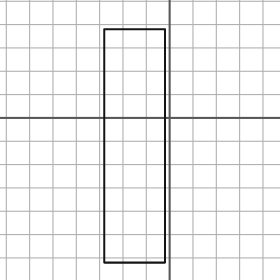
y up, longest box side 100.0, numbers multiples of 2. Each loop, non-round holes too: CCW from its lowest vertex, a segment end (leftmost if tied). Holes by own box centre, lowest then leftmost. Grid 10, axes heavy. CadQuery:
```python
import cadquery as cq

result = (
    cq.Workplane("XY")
    .moveTo(-28.0, -62.0)
    .lineTo(-2.0, -62.0)
    .lineTo(-2.0, 38.0)
    .lineTo(-28.0, 38.0)
    .close()
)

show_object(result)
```